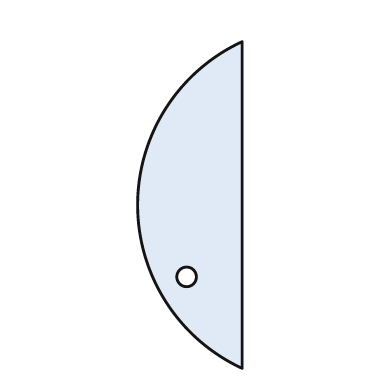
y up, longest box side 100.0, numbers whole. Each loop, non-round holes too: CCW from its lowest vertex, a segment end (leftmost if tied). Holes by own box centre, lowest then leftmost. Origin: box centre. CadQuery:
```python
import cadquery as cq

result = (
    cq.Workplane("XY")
    .moveTo(16.0, -50.0)
    .lineTo(16.0, 50.0)
    .threePointArc((-16.0, 0.0), (16.0, -50.0))
    .close()
    .moveTo(-1.0, -22.0)
    .circle(3.0)
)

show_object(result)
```